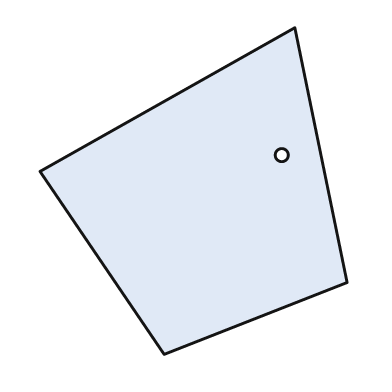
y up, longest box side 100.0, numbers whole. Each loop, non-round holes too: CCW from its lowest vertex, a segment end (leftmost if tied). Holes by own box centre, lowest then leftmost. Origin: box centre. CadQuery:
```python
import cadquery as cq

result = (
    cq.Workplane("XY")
    .moveTo(-9.0, -50.0)
    .lineTo(47.0, -28.0)
    .lineTo(31.0, 50.0)
    .lineTo(-47.0, 6.0)
    .close()
    .moveTo(27.0, 11.0)
    .circle(2.0)
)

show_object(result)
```